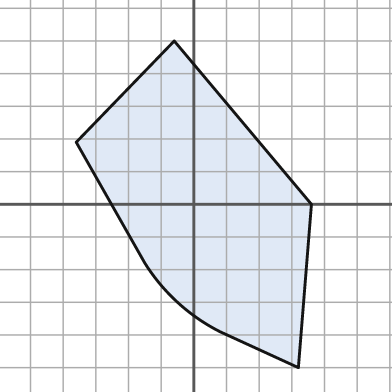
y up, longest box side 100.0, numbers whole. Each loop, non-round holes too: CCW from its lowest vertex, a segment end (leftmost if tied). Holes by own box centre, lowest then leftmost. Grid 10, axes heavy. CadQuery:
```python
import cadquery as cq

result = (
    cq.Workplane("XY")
    .moveTo(32.0, -50.0)
    .lineTo(36.0, 0.0)
    .lineTo(-6.0, 50.0)
    .lineTo(-36.0, 19.0)
    .lineTo(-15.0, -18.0)
    .threePointArc((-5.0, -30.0), (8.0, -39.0))
    .close()
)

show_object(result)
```